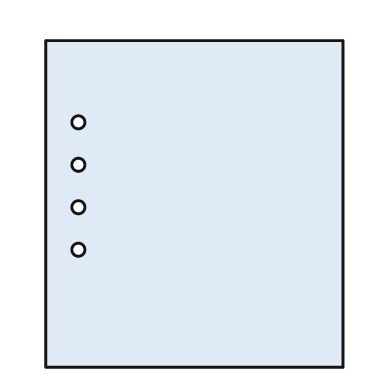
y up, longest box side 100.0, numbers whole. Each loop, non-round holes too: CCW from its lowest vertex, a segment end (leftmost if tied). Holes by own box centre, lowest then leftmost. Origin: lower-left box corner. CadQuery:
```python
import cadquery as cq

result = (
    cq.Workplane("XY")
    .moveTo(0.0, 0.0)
    .lineTo(91.0, 0.0)
    .lineTo(91.0, 100.0)
    .lineTo(0.0, 100.0)
    .close()
    .moveTo(10.0, 36.0)
    .circle(2.0)
    .moveTo(10.0, 49.0)
    .circle(2.0)
    .moveTo(10.0, 62.0)
    .circle(2.0)
    .moveTo(10.0, 75.0)
    .circle(2.0)
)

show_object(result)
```